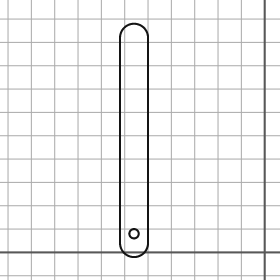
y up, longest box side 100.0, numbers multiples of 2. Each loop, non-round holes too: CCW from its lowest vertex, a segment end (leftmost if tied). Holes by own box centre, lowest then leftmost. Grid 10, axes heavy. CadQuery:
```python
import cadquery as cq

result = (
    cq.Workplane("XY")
    .moveTo(-62.0, 4.0)
    .threePointArc((-56.0, -2.0), (-50.0, 4.0))
    .lineTo(-50.0, 92.0)
    .threePointArc((-56.0, 98.0), (-62.0, 92.0))
    .close()
    .moveTo(-56.0, 8.0)
    .circle(2.0)
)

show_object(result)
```